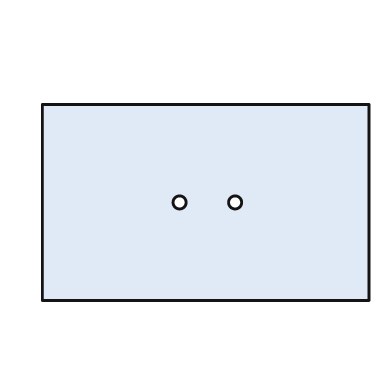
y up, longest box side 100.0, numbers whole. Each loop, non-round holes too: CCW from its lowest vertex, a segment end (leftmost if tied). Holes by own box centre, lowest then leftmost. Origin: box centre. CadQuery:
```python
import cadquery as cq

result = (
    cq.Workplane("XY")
    .moveTo(-50.0, -30.0)
    .lineTo(50.0, -30.0)
    .lineTo(50.0, 30.0)
    .lineTo(-50.0, 30.0)
    .close()
    .moveTo(-8.0, 0.0)
    .circle(2.0)
    .moveTo(9.0, 0.0)
    .circle(2.0)
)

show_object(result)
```